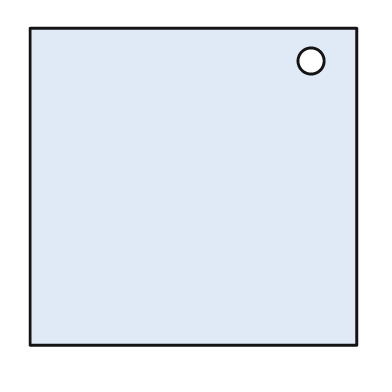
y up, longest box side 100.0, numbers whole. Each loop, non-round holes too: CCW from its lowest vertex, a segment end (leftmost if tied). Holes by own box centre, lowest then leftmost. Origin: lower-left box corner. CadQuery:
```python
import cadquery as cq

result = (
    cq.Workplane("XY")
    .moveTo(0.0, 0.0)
    .lineTo(100.0, 0.0)
    .lineTo(100.0, 97.0)
    .lineTo(0.0, 97.0)
    .close()
    .moveTo(86.0, 87.0)
    .circle(4.0)
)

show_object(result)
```